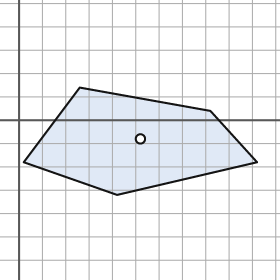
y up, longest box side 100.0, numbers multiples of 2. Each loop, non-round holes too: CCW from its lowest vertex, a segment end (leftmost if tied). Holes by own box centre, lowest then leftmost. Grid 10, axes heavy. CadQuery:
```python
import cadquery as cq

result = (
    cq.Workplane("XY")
    .moveTo(42.0, -32.0)
    .lineTo(102.0, -18.0)
    .lineTo(82.0, 4.0)
    .lineTo(26.0, 14.0)
    .lineTo(2.0, -18.0)
    .close()
    .moveTo(52.0, -8.0)
    .circle(2.0)
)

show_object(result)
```